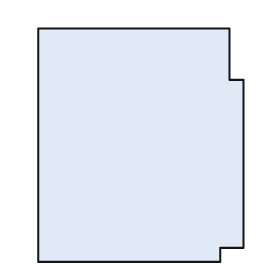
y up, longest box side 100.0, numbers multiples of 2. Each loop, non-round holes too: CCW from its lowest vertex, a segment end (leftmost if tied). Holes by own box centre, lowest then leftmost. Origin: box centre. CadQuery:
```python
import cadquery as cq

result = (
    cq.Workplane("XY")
    .moveTo(-44.0, -50.0)
    .lineTo(34.0, -50.0)
    .lineTo(34.0, -44.0)
    .lineTo(44.0, -44.0)
    .lineTo(44.0, 28.0)
    .lineTo(38.0, 28.0)
    .lineTo(38.0, 50.0)
    .lineTo(-44.0, 50.0)
    .close()
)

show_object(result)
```